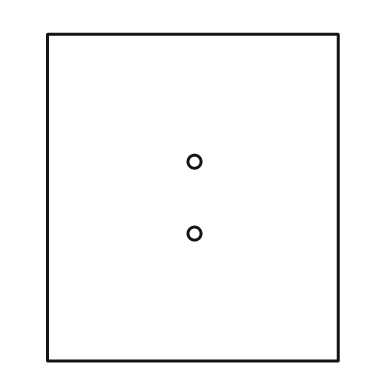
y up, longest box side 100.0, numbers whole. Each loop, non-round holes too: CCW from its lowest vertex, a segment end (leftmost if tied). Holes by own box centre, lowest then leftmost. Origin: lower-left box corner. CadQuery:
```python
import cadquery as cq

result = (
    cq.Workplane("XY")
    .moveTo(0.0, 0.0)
    .lineTo(89.0, 0.0)
    .lineTo(89.0, 100.0)
    .lineTo(0.0, 100.0)
    .close()
    .moveTo(45.0, 39.0)
    .circle(2.0)
    .moveTo(45.0, 61.0)
    .circle(2.0)
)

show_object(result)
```